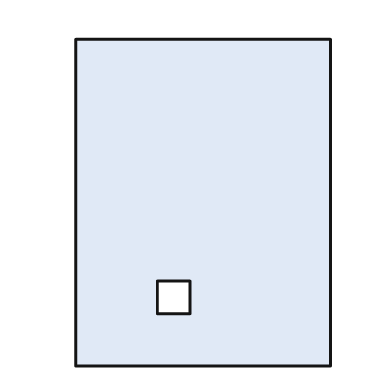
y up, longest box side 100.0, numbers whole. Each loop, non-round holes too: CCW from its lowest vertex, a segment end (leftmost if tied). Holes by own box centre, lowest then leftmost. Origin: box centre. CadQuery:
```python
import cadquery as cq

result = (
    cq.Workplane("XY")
    .moveTo(-39.0, -50.0)
    .lineTo(39.0, -50.0)
    .lineTo(39.0, 50.0)
    .lineTo(-39.0, 50.0)
    .close()
    .moveTo(-14.0, -34.0)
    .lineTo(-4.0, -34.0)
    .lineTo(-4.0, -24.0)
    .lineTo(-14.0, -24.0)
    .close()
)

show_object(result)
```